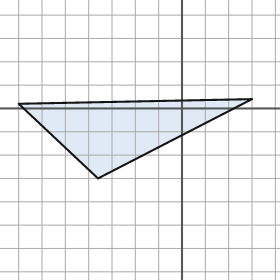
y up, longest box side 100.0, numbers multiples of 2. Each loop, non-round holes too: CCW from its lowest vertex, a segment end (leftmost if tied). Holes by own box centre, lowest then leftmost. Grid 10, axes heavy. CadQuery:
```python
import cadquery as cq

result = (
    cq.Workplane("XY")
    .moveTo(-36.0, -30.0)
    .lineTo(30.0, 4.0)
    .lineTo(-70.0, 2.0)
    .close()
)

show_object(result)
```